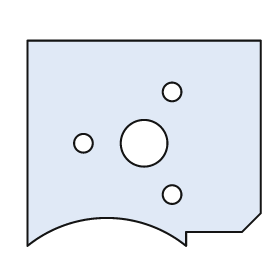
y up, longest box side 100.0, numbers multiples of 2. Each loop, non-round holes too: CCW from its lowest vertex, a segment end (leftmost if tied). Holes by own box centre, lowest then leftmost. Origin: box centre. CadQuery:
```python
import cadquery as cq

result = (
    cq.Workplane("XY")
    .moveTo(-50.0, -44.0)
    .threePointArc((-16.0, -32.0), (18.0, -44.0))
    .lineTo(18.0, -38.0)
    .lineTo(42.0, -38.0)
    .lineTo(50.0, -30.0)
    .lineTo(50.0, 44.0)
    .lineTo(-50.0, 44.0)
    .close()
    .moveTo(12.0, -22.0)
    .circle(4.0)
    .moveTo(-26.0, 0.0)
    .circle(4.0)
    .moveTo(0.0, 0.0)
    .circle(10.0)
    .moveTo(12.0, 22.0)
    .circle(4.0)
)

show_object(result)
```